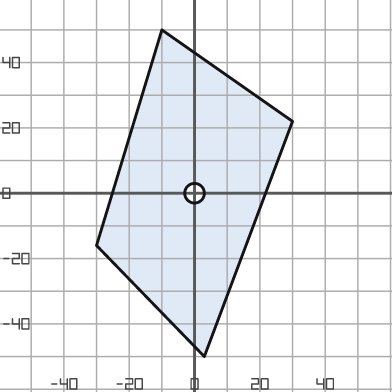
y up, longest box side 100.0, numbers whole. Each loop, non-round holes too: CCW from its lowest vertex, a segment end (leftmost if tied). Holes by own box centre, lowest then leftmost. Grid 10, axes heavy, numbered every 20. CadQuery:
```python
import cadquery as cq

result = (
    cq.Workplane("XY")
    .moveTo(3.0, -50.0)
    .lineTo(30.0, 22.0)
    .lineTo(-10.0, 50.0)
    .lineTo(-30.0, -16.0)
    .close()
    .moveTo(0.0, 0.0)
    .circle(3.0)
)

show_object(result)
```